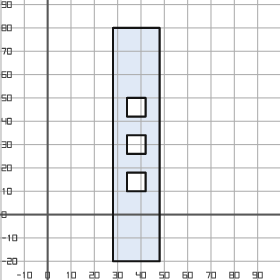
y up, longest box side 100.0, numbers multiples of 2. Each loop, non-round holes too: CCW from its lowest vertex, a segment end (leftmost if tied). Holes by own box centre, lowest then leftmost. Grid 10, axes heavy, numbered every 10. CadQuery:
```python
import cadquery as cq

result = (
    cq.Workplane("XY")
    .moveTo(28.0, -20.0)
    .lineTo(48.0, -20.0)
    .lineTo(48.0, 80.0)
    .lineTo(28.0, 80.0)
    .close()
    .moveTo(34.0, 10.0)
    .lineTo(42.0, 10.0)
    .lineTo(42.0, 18.0)
    .lineTo(34.0, 18.0)
    .close()
    .moveTo(34.0, 26.0)
    .lineTo(42.0, 26.0)
    .lineTo(42.0, 34.0)
    .lineTo(34.0, 34.0)
    .close()
    .moveTo(34.0, 42.0)
    .lineTo(42.0, 42.0)
    .lineTo(42.0, 50.0)
    .lineTo(34.0, 50.0)
    .close()
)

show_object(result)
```